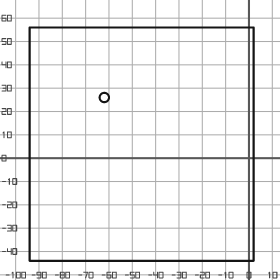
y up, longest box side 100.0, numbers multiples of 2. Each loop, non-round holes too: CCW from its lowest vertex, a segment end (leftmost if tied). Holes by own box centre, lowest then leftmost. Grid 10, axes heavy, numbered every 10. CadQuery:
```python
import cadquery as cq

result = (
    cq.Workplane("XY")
    .moveTo(-94.0, -44.0)
    .lineTo(2.0, -44.0)
    .lineTo(2.0, 56.0)
    .lineTo(-94.0, 56.0)
    .close()
    .moveTo(-62.0, 26.0)
    .circle(2.0)
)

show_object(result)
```